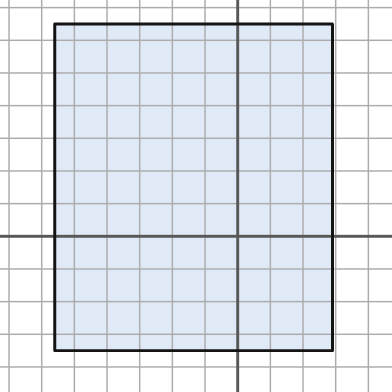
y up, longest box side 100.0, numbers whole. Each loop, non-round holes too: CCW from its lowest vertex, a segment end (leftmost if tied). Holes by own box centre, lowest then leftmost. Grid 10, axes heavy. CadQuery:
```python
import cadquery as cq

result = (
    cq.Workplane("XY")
    .moveTo(-56.0, -35.0)
    .lineTo(29.0, -35.0)
    .lineTo(29.0, 65.0)
    .lineTo(-56.0, 65.0)
    .close()
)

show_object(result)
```